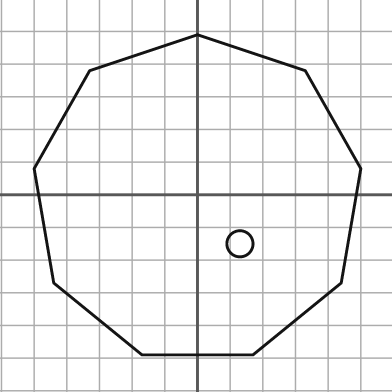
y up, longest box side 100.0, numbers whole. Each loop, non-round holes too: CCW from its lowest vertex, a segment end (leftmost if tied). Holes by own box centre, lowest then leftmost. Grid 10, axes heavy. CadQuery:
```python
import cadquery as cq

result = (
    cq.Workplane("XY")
    .moveTo(-17.0, -49.0)
    .lineTo(17.0, -49.0)
    .lineTo(44.0, -27.0)
    .lineTo(50.0, 8.0)
    .lineTo(33.0, 38.0)
    .lineTo(0.0, 49.0)
    .lineTo(-33.0, 38.0)
    .lineTo(-50.0, 8.0)
    .lineTo(-44.0, -27.0)
    .close()
    .moveTo(13.0, -15.0)
    .circle(4.0)
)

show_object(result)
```